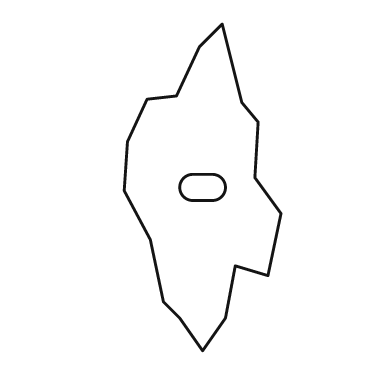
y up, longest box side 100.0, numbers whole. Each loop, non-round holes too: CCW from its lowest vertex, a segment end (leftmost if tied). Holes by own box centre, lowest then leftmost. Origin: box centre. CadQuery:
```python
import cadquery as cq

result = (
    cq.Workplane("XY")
    .moveTo(0.0, -50.0)
    .lineTo(7.0, -40.0)
    .lineTo(10.0, -24.0)
    .lineTo(20.0, -27.0)
    .lineTo(24.0, -8.0)
    .lineTo(16.0, 3.0)
    .lineTo(17.0, 20.0)
    .lineTo(12.0, 26.0)
    .lineTo(6.0, 50.0)
    .lineTo(-1.0, 43.0)
    .lineTo(-8.0, 28.0)
    .lineTo(-17.0, 27.0)
    .lineTo(-23.0, 14.0)
    .lineTo(-24.0, -1.0)
    .lineTo(-16.0, -16.0)
    .lineTo(-12.0, -35.0)
    .lineTo(-7.0, -40.0)
    .close()
    .moveTo(-3.0, -4.0)
    .lineTo(3.0, -4.0)
    .threePointArc((7.0, 0.0), (3.0, 4.0))
    .lineTo(-3.0, 4.0)
    .threePointArc((-7.0, 0.0), (-3.0, -4.0))
    .close()
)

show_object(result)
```